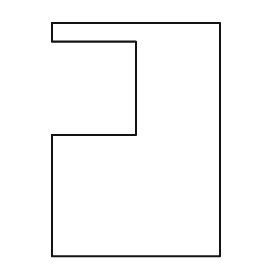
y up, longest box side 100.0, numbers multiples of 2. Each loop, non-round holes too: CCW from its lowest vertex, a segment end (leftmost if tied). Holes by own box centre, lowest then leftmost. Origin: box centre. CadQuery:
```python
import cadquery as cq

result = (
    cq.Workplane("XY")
    .moveTo(-36.0, -50.0)
    .lineTo(36.0, -50.0)
    .lineTo(36.0, 50.0)
    .lineTo(-36.0, 50.0)
    .lineTo(-36.0, 42.0)
    .lineTo(0.0, 42.0)
    .lineTo(0.0, 2.0)
    .lineTo(-36.0, 2.0)
    .close()
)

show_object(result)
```